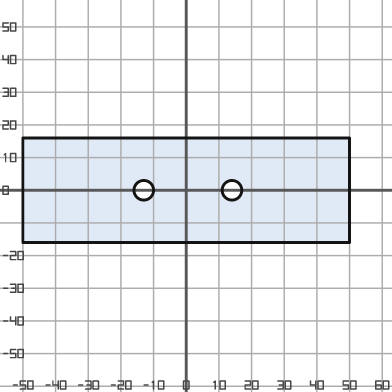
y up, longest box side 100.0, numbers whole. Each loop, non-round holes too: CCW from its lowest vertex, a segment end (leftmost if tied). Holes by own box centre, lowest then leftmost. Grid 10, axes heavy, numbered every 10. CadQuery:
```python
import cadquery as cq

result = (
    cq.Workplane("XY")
    .moveTo(-50.0, -16.0)
    .lineTo(50.0, -16.0)
    .lineTo(50.0, 16.0)
    .lineTo(-50.0, 16.0)
    .close()
    .moveTo(-13.0, 0.0)
    .circle(3.0)
    .moveTo(14.0, 0.0)
    .circle(3.0)
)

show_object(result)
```